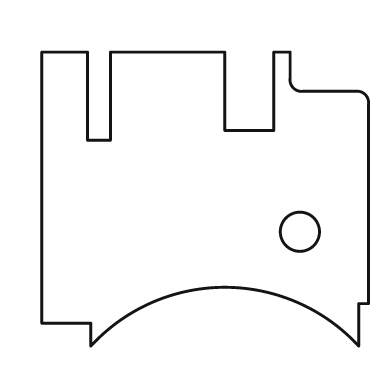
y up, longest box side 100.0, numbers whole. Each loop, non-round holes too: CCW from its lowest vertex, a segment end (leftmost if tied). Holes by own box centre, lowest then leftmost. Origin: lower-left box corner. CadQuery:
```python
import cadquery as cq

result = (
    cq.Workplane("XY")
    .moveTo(15.0, 0.0)
    .threePointArc((56.0, 18.0), (97.0, 0.0))
    .lineTo(97.0, 13.0)
    .lineTo(100.0, 13.0)
    .lineTo(100.0, 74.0)
    .threePointArc((99.0, 77.0), (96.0, 78.0))
    .lineTo(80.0, 78.0)
    .threePointArc((77.0, 79.0), (76.0, 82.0))
    .lineTo(76.0, 90.0)
    .lineTo(71.0, 90.0)
    .lineTo(71.0, 66.0)
    .lineTo(56.0, 66.0)
    .lineTo(56.0, 90.0)
    .lineTo(21.0, 90.0)
    .lineTo(21.0, 63.0)
    .lineTo(14.0, 63.0)
    .lineTo(14.0, 90.0)
    .lineTo(0.0, 90.0)
    .lineTo(0.0, 7.0)
    .lineTo(15.0, 7.0)
    .close()
    .moveTo(79.0, 35.0)
    .circle(6.0)
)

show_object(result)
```